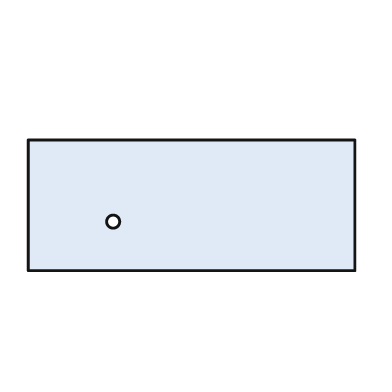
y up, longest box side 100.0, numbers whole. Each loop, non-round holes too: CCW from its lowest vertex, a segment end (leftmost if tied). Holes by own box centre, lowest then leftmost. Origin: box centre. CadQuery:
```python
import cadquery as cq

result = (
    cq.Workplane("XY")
    .moveTo(-50.0, -20.0)
    .lineTo(50.0, -20.0)
    .lineTo(50.0, 20.0)
    .lineTo(-50.0, 20.0)
    .close()
    .moveTo(-24.0, -5.0)
    .circle(2.0)
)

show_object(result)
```